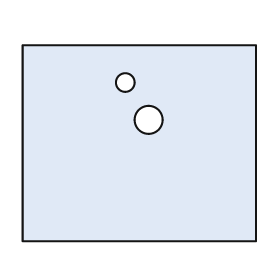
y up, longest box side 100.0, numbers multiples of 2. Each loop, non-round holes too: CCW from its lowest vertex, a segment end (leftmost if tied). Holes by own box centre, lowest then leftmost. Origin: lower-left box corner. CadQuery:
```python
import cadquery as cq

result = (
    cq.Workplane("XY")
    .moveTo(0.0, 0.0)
    .lineTo(100.0, 0.0)
    .lineTo(100.0, 84.0)
    .lineTo(0.0, 84.0)
    .close()
    .moveTo(54.0, 52.0)
    .circle(6.0)
    .moveTo(44.0, 68.0)
    .circle(4.0)
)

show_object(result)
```